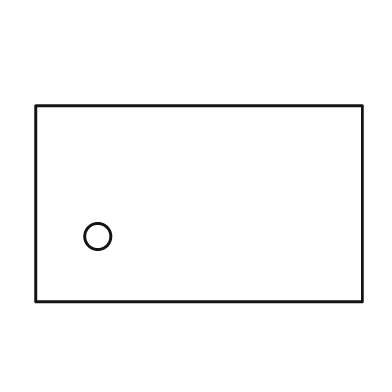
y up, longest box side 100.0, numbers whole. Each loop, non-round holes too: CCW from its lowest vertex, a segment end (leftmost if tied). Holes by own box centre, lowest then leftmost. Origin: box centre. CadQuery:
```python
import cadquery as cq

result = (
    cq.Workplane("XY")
    .moveTo(-50.0, -30.0)
    .lineTo(50.0, -30.0)
    .lineTo(50.0, 30.0)
    .lineTo(-50.0, 30.0)
    .close()
    .moveTo(-31.0, -10.0)
    .circle(4.0)
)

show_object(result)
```